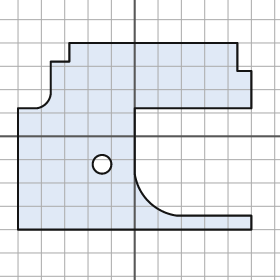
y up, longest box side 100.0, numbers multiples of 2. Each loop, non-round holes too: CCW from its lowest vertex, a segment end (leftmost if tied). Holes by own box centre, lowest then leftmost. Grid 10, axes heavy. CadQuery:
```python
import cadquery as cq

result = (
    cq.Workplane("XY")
    .moveTo(-50.0, -40.0)
    .lineTo(50.0, -40.0)
    .lineTo(50.0, -34.0)
    .lineTo(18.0, -34.0)
    .threePointArc((6.0, -28.0), (0.0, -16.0))
    .lineTo(0.0, 12.0)
    .lineTo(50.0, 12.0)
    .lineTo(50.0, 28.0)
    .lineTo(44.0, 28.0)
    .lineTo(44.0, 40.0)
    .lineTo(-28.0, 40.0)
    .lineTo(-28.0, 32.0)
    .lineTo(-36.0, 32.0)
    .lineTo(-36.0, 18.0)
    .threePointArc((-38.0, 14.0), (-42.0, 12.0))
    .lineTo(-50.0, 12.0)
    .close()
    .moveTo(-14.0, -12.0)
    .circle(4.0)
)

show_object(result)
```